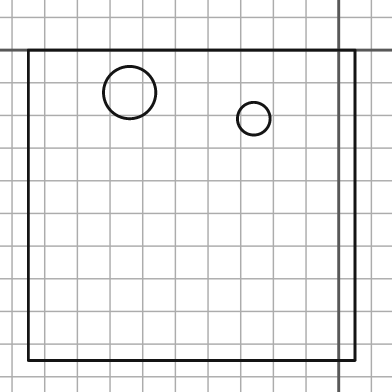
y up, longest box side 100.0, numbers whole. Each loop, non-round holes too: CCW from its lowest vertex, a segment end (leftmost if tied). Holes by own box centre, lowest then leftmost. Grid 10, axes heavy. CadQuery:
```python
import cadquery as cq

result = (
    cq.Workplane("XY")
    .moveTo(-95.0, -95.0)
    .lineTo(5.0, -95.0)
    .lineTo(5.0, 0.0)
    .lineTo(-95.0, 0.0)
    .close()
    .moveTo(-26.0, -21.0)
    .circle(5.0)
    .moveTo(-64.0, -13.0)
    .circle(8.0)
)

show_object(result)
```